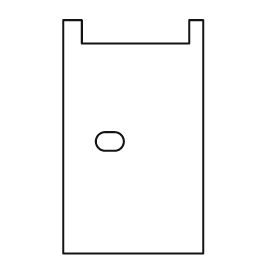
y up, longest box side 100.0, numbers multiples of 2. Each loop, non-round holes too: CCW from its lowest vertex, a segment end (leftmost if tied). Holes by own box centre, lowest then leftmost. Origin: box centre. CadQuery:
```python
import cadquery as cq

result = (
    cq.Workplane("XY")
    .moveTo(-30.0, -50.0)
    .lineTo(30.0, -50.0)
    .lineTo(30.0, 50.0)
    .lineTo(24.0, 50.0)
    .lineTo(24.0, 40.0)
    .lineTo(-22.0, 40.0)
    .lineTo(-22.0, 50.0)
    .lineTo(-30.0, 50.0)
    .close()
    .moveTo(-12.0, -6.0)
    .lineTo(-8.0, -6.0)
    .threePointArc((-4.0, -2.0), (-8.0, 2.0))
    .lineTo(-12.0, 2.0)
    .threePointArc((-16.0, -2.0), (-12.0, -6.0))
    .close()
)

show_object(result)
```